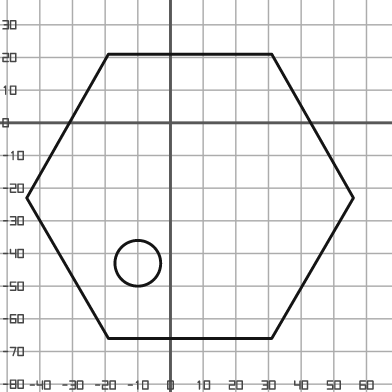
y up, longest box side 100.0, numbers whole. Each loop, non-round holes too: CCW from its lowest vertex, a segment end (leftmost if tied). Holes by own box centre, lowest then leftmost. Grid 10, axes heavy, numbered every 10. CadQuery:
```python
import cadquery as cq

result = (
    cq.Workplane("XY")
    .moveTo(-19.0, -66.0)
    .lineTo(31.0, -66.0)
    .lineTo(56.0, -23.0)
    .lineTo(31.0, 21.0)
    .lineTo(-19.0, 21.0)
    .lineTo(-44.0, -23.0)
    .close()
    .moveTo(-10.0, -43.0)
    .circle(7.0)
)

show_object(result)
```